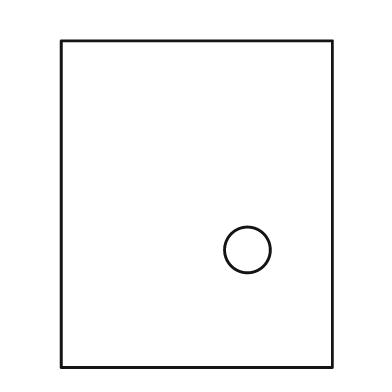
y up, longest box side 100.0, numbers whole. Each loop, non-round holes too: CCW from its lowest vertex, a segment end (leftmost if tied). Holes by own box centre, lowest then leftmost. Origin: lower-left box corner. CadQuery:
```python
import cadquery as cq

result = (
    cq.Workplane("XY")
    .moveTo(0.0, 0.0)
    .lineTo(83.0, 0.0)
    .lineTo(83.0, 100.0)
    .lineTo(0.0, 100.0)
    .close()
    .moveTo(57.0, 36.0)
    .circle(7.0)
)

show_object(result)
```